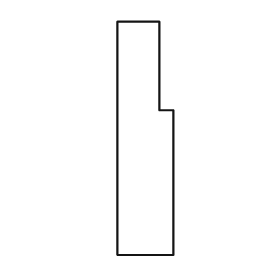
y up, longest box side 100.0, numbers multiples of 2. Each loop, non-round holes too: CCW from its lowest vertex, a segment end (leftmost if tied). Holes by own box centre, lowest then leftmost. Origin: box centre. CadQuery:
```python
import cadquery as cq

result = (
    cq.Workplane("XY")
    .moveTo(-12.0, -50.0)
    .lineTo(12.0, -50.0)
    .lineTo(12.0, 12.0)
    .lineTo(6.0, 12.0)
    .lineTo(6.0, 50.0)
    .lineTo(-12.0, 50.0)
    .close()
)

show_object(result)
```